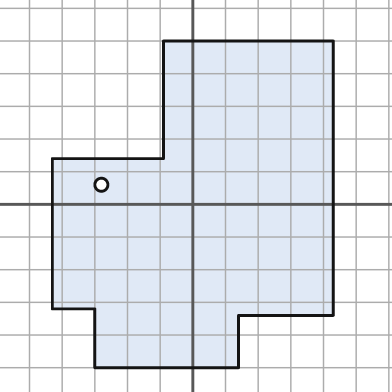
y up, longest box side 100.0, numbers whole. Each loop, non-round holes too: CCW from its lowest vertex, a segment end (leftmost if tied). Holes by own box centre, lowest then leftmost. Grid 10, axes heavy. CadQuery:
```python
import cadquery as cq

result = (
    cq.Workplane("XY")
    .moveTo(-30.0, -50.0)
    .lineTo(14.0, -50.0)
    .lineTo(14.0, -34.0)
    .lineTo(43.0, -34.0)
    .lineTo(43.0, 50.0)
    .lineTo(-9.0, 50.0)
    .lineTo(-9.0, 14.0)
    .lineTo(-43.0, 14.0)
    .lineTo(-43.0, -32.0)
    .lineTo(-30.0, -32.0)
    .close()
    .moveTo(-28.0, 6.0)
    .circle(2.0)
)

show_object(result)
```